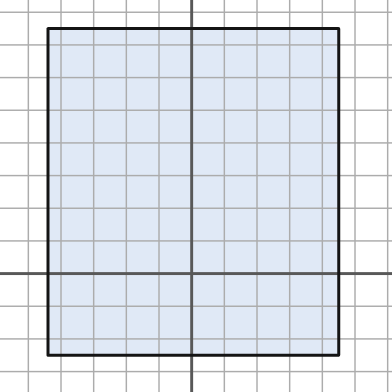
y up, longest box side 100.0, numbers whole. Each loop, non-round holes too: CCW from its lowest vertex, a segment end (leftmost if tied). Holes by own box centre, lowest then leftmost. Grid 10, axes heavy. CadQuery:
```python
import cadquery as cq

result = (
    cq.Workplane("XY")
    .moveTo(-44.0, -25.0)
    .lineTo(45.0, -25.0)
    .lineTo(45.0, 75.0)
    .lineTo(-44.0, 75.0)
    .close()
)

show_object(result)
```